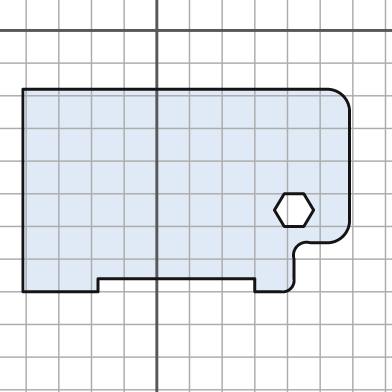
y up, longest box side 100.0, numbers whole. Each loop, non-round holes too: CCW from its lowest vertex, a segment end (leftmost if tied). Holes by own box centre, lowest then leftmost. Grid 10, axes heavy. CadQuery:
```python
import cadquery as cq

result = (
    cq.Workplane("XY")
    .moveTo(-41.0, -80.0)
    .lineTo(-18.0, -80.0)
    .lineTo(-18.0, -76.0)
    .lineTo(30.0, -76.0)
    .lineTo(30.0, -80.0)
    .lineTo(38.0, -80.0)
    .threePointArc((41.0, -79.0), (42.0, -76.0))
    .lineTo(42.0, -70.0)
    .threePointArc((43.0, -66.0), (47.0, -65.0))
    .lineTo(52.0, -65.0)
    .threePointArc((57.0, -63.0), (59.0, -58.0))
    .lineTo(59.0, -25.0)
    .threePointArc((57.0, -20.0), (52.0, -18.0))
    .lineTo(-41.0, -18.0)
    .close()
    .moveTo(39.0, -60.0)
    .lineTo(45.0, -60.0)
    .lineTo(48.0, -55.0)
    .lineTo(45.0, -50.0)
    .lineTo(39.0, -50.0)
    .lineTo(36.0, -55.0)
    .close()
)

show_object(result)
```